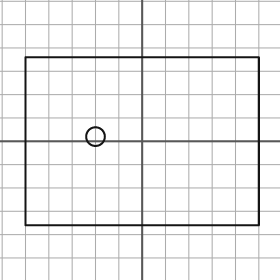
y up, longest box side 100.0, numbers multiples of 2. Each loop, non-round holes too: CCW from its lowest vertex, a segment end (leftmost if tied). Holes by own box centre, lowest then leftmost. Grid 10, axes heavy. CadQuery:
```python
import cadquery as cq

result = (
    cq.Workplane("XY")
    .moveTo(-50.0, -36.0)
    .lineTo(50.0, -36.0)
    .lineTo(50.0, 36.0)
    .lineTo(-50.0, 36.0)
    .close()
    .moveTo(-20.0, 2.0)
    .circle(4.0)
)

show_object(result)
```